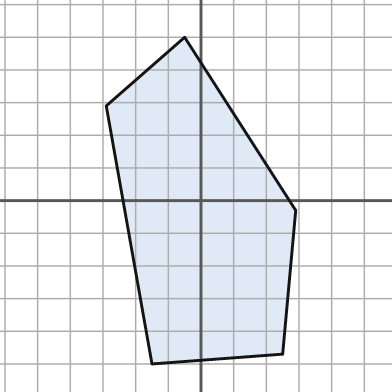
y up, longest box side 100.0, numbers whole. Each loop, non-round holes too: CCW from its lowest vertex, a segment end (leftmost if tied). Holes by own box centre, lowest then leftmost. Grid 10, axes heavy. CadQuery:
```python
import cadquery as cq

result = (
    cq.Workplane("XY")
    .moveTo(-15.0, -50.0)
    .lineTo(25.0, -47.0)
    .lineTo(29.0, -3.0)
    .lineTo(-5.0, 50.0)
    .lineTo(-29.0, 29.0)
    .close()
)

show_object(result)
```